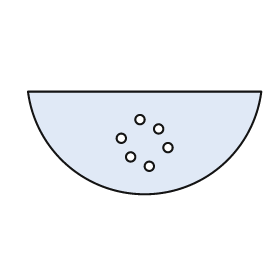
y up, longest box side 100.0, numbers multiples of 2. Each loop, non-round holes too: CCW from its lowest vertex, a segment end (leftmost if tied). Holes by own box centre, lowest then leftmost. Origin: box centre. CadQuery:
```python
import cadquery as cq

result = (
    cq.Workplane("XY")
    .moveTo(-50.0, 22.0)
    .threePointArc((0.0, -22.0), (50.0, 22.0))
    .close()
    .moveTo(2.0, -10.0)
    .circle(2.0)
    .moveTo(-6.0, -6.0)
    .circle(2.0)
    .moveTo(10.0, -2.0)
    .circle(2.0)
    .moveTo(-10.0, 2.0)
    .circle(2.0)
    .moveTo(6.0, 6.0)
    .circle(2.0)
    .moveTo(-2.0, 10.0)
    .circle(2.0)
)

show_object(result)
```